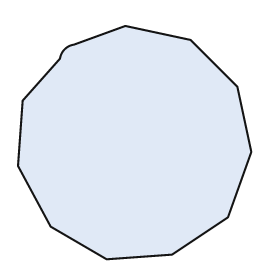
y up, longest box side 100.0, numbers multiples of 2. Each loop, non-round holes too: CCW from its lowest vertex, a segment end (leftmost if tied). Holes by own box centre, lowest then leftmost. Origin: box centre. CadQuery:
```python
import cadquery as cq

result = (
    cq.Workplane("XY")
    .moveTo(-12.0, -50.0)
    .lineTo(16.0, -48.0)
    .lineTo(40.0, -32.0)
    .lineTo(50.0, -4.0)
    .lineTo(44.0, 24.0)
    .lineTo(24.0, 44.0)
    .lineTo(-4.0, 50.0)
    .lineTo(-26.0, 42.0)
    .threePointArc((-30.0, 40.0), (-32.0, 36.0))
    .lineTo(-48.0, 18.0)
    .lineTo(-50.0, -10.0)
    .lineTo(-36.0, -36.0)
    .close()
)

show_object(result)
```